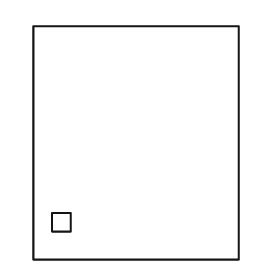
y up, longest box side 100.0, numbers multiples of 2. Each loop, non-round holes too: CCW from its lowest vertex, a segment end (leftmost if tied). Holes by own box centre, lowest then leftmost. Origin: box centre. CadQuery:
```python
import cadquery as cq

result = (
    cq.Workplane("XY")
    .moveTo(-44.0, -50.0)
    .lineTo(44.0, -50.0)
    .lineTo(44.0, 50.0)
    .lineTo(-44.0, 50.0)
    .close()
    .moveTo(-36.0, -38.0)
    .lineTo(-28.0, -38.0)
    .lineTo(-28.0, -30.0)
    .lineTo(-36.0, -30.0)
    .close()
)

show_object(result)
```